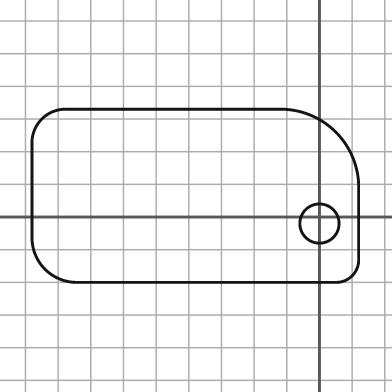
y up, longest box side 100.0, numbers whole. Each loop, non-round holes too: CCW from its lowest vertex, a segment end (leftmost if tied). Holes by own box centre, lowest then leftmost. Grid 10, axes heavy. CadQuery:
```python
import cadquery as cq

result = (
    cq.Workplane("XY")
    .moveTo(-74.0, -20.0)
    .lineTo(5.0, -20.0)
    .threePointArc((10.0, -18.0), (12.0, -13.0))
    .lineTo(12.0, 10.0)
    .threePointArc((5.0, 26.0), (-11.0, 33.0))
    .lineTo(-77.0, 33.0)
    .threePointArc((-85.0, 30.0), (-88.0, 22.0))
    .lineTo(-88.0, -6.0)
    .threePointArc((-84.0, -16.0), (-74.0, -20.0))
    .close()
    .moveTo(0.0, -2.0)
    .circle(6.0)
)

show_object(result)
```